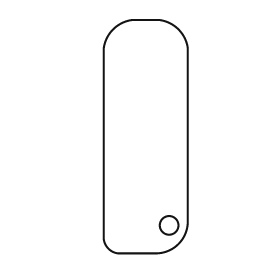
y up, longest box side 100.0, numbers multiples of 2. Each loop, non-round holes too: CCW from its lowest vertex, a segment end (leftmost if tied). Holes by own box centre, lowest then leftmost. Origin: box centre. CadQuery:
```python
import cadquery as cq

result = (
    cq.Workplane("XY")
    .moveTo(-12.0, -50.0)
    .lineTo(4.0, -50.0)
    .threePointArc((14.0, -46.0), (18.0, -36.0))
    .lineTo(18.0, 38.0)
    .threePointArc((14.0, 46.0), (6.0, 50.0))
    .lineTo(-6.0, 50.0)
    .threePointArc((-14.0, 46.0), (-18.0, 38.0))
    .lineTo(-18.0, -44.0)
    .threePointArc((-16.0, -48.0), (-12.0, -50.0))
    .close()
    .moveTo(10.0, -38.0)
    .circle(4.0)
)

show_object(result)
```